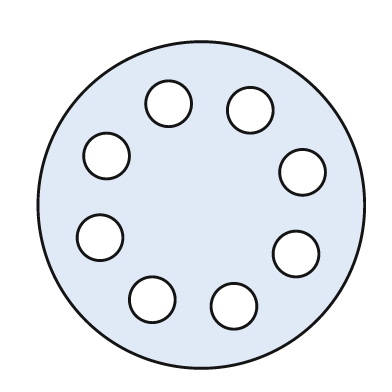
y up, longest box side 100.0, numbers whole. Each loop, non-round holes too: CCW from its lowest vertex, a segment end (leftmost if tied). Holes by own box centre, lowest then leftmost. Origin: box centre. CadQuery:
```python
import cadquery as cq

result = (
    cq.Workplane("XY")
    .moveTo(0.0, 0.0)
    .circle(50.0)
    .moveTo(10.0, -31.0)
    .circle(7.0)
    .moveTo(-15.0, -29.0)
    .circle(7.0)
    .moveTo(29.0, -15.0)
    .circle(7.0)
    .moveTo(-31.0, -10.0)
    .circle(7.0)
    .moveTo(31.0, 10.0)
    .circle(7.0)
    .moveTo(-29.0, 15.0)
    .circle(7.0)
    .moveTo(15.0, 29.0)
    .circle(7.0)
    .moveTo(-10.0, 31.0)
    .circle(7.0)
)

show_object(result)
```